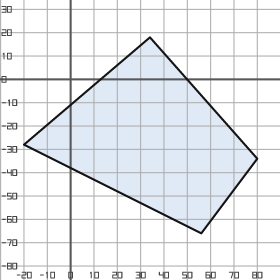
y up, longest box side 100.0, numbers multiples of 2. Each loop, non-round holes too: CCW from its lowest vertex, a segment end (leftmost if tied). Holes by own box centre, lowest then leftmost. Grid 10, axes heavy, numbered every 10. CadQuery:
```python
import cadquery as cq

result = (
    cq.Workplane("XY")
    .moveTo(56.0, -66.0)
    .lineTo(80.0, -34.0)
    .lineTo(34.0, 18.0)
    .lineTo(-20.0, -28.0)
    .close()
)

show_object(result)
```